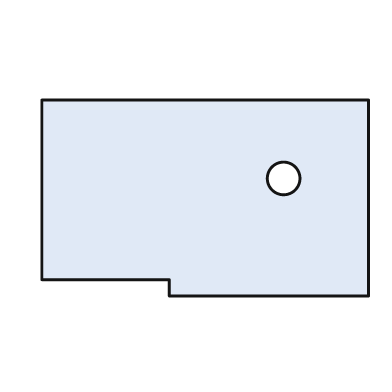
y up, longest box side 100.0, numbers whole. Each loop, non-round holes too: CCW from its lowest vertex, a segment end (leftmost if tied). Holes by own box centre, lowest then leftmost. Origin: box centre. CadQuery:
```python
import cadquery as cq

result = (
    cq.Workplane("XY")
    .moveTo(-11.0, -30.0)
    .lineTo(50.0, -30.0)
    .lineTo(50.0, 30.0)
    .lineTo(-50.0, 30.0)
    .lineTo(-50.0, -25.0)
    .lineTo(-11.0, -25.0)
    .close()
    .moveTo(24.0, 6.0)
    .circle(5.0)
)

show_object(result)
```